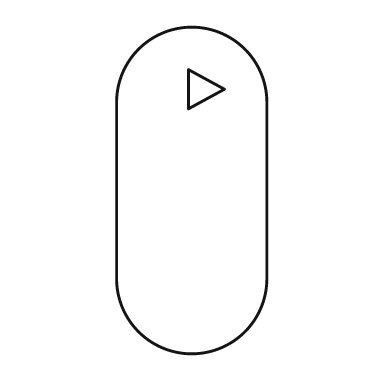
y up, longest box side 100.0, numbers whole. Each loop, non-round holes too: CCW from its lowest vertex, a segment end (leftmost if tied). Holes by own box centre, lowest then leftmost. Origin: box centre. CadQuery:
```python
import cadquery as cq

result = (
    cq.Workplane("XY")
    .moveTo(-23.0, -27.0)
    .threePointArc((0.0, -50.0), (23.0, -27.0))
    .lineTo(23.0, 27.0)
    .threePointArc((0.0, 50.0), (-23.0, 27.0))
    .close()
    .moveTo(-1.0, 25.0)
    .lineTo(10.0, 31.0)
    .lineTo(-1.0, 37.0)
    .close()
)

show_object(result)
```